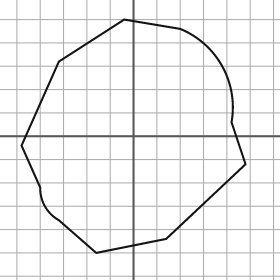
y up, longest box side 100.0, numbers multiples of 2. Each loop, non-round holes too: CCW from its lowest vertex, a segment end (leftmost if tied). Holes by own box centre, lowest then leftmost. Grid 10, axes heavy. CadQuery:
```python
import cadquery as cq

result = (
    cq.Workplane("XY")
    .moveTo(-16.0, -50.0)
    .lineTo(14.0, -44.0)
    .lineTo(48.0, -12.0)
    .lineTo(42.0, 6.0)
    .threePointArc((38.0, 30.0), (20.0, 46.0))
    .lineTo(-4.0, 50.0)
    .lineTo(-32.0, 32.0)
    .lineTo(-48.0, -4.0)
    .lineTo(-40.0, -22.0)
    .threePointArc((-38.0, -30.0), (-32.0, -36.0))
    .close()
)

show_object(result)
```